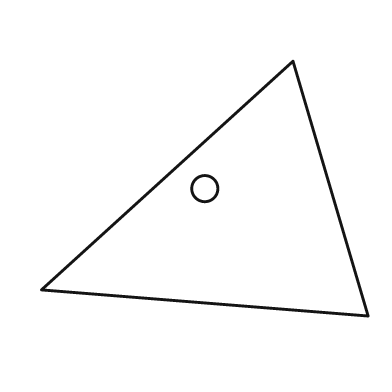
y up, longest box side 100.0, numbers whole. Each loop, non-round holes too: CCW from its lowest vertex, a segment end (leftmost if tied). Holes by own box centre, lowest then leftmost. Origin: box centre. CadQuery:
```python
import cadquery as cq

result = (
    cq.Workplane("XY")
    .moveTo(50.0, -39.0)
    .lineTo(27.0, 39.0)
    .lineTo(-50.0, -31.0)
    .close()
    .moveTo(0.0, 0.0)
    .circle(4.0)
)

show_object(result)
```